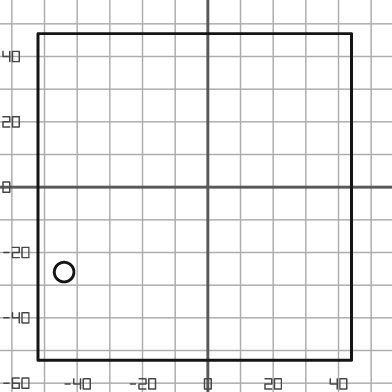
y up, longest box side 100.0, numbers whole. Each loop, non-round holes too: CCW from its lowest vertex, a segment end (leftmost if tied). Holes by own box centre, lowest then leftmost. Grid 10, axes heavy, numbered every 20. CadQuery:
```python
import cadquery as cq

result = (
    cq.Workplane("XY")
    .moveTo(-52.0, -53.0)
    .lineTo(44.0, -53.0)
    .lineTo(44.0, 47.0)
    .lineTo(-52.0, 47.0)
    .close()
    .moveTo(-44.0, -26.0)
    .circle(3.0)
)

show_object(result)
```